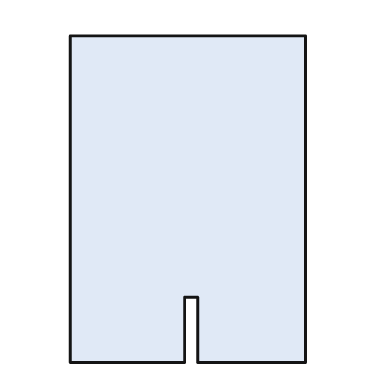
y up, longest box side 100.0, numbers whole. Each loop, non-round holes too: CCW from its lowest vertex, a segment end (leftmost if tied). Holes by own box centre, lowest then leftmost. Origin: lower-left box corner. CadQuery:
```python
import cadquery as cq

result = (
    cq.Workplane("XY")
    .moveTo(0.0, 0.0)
    .lineTo(35.0, 0.0)
    .lineTo(35.0, 20.0)
    .lineTo(39.0, 20.0)
    .lineTo(39.0, 0.0)
    .lineTo(72.0, 0.0)
    .lineTo(72.0, 100.0)
    .lineTo(0.0, 100.0)
    .close()
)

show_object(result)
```